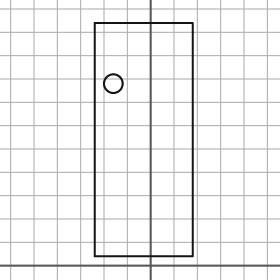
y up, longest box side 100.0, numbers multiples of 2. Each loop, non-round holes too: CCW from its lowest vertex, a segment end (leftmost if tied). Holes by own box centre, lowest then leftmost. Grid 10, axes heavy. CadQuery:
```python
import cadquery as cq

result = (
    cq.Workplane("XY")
    .moveTo(-24.0, 4.0)
    .lineTo(18.0, 4.0)
    .lineTo(18.0, 104.0)
    .lineTo(-24.0, 104.0)
    .close()
    .moveTo(-16.0, 78.0)
    .circle(4.0)
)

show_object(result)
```